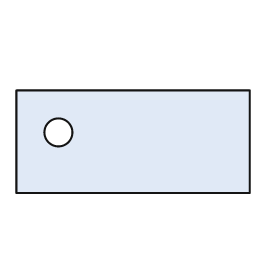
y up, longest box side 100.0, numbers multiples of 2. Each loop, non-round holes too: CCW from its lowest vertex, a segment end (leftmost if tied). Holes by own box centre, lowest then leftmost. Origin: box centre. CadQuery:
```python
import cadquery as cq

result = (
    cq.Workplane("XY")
    .moveTo(-50.0, -22.0)
    .lineTo(50.0, -22.0)
    .lineTo(50.0, 22.0)
    .lineTo(-50.0, 22.0)
    .close()
    .moveTo(-32.0, 4.0)
    .circle(6.0)
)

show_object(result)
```